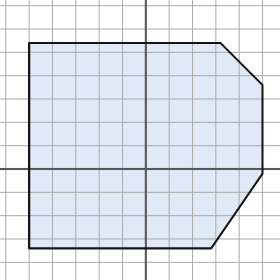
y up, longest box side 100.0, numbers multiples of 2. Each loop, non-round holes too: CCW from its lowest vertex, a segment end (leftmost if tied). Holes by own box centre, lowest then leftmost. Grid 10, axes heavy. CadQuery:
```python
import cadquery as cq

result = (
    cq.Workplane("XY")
    .moveTo(-50.0, -34.0)
    .lineTo(28.0, -34.0)
    .lineTo(50.0, -2.0)
    .lineTo(50.0, 36.0)
    .lineTo(32.0, 54.0)
    .lineTo(-50.0, 54.0)
    .close()
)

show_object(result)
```